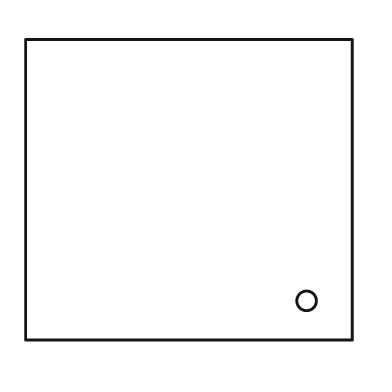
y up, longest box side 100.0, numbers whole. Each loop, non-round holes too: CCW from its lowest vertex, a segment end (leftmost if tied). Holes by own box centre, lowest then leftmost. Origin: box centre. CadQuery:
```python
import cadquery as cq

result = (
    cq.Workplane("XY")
    .moveTo(-50.0, -46.0)
    .lineTo(50.0, -46.0)
    .lineTo(50.0, 46.0)
    .lineTo(-50.0, 46.0)
    .close()
    .moveTo(36.0, -34.0)
    .circle(3.0)
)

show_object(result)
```